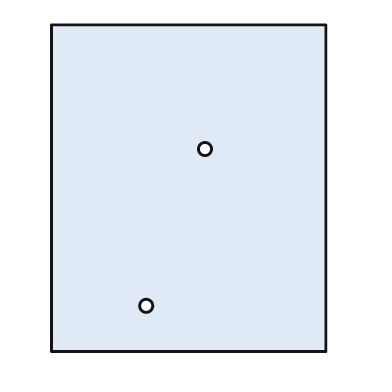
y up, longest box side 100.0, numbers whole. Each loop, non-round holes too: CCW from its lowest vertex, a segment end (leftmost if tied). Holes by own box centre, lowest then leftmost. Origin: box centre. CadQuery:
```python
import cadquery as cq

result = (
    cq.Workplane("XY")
    .moveTo(-42.0, -50.0)
    .lineTo(42.0, -50.0)
    .lineTo(42.0, 50.0)
    .lineTo(-42.0, 50.0)
    .close()
    .moveTo(-13.0, -36.0)
    .circle(2.0)
    .moveTo(5.0, 12.0)
    .circle(2.0)
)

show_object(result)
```